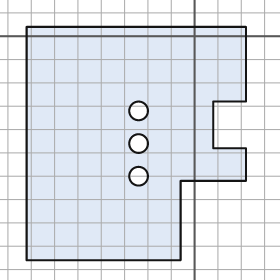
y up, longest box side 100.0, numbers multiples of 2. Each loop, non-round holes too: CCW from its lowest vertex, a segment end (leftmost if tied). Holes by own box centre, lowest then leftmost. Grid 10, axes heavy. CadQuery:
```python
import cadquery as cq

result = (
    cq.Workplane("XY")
    .moveTo(-72.0, -96.0)
    .lineTo(-6.0, -96.0)
    .lineTo(-6.0, -62.0)
    .lineTo(22.0, -62.0)
    .lineTo(22.0, -48.0)
    .lineTo(8.0, -48.0)
    .lineTo(8.0, -28.0)
    .lineTo(22.0, -28.0)
    .lineTo(22.0, 4.0)
    .lineTo(-72.0, 4.0)
    .close()
    .moveTo(-24.0, -60.0)
    .circle(4.0)
    .moveTo(-24.0, -46.0)
    .circle(4.0)
    .moveTo(-24.0, -32.0)
    .circle(4.0)
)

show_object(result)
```